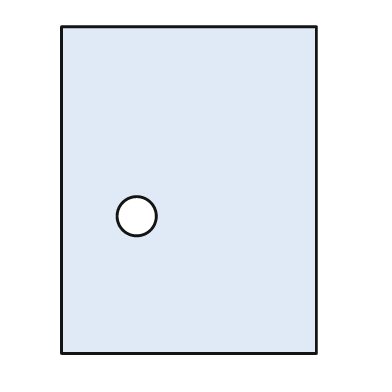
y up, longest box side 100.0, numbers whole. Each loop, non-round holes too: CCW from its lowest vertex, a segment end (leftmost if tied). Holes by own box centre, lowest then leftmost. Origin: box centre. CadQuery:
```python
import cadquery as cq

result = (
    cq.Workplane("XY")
    .moveTo(-39.0, -50.0)
    .lineTo(39.0, -50.0)
    .lineTo(39.0, 50.0)
    .lineTo(-39.0, 50.0)
    .close()
    .moveTo(-16.0, -8.0)
    .circle(6.0)
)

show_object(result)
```